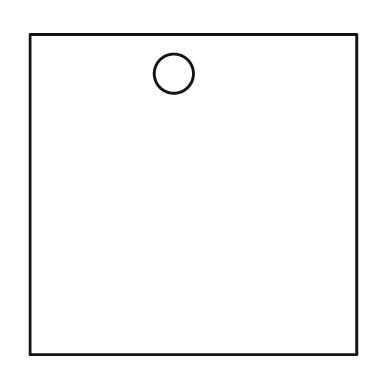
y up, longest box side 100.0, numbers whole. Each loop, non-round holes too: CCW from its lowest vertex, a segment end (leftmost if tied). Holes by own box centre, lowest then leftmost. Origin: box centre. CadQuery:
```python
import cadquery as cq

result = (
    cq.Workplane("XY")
    .moveTo(-50.0, -49.0)
    .lineTo(50.0, -49.0)
    .lineTo(50.0, 49.0)
    .lineTo(-50.0, 49.0)
    .close()
    .moveTo(-6.0, 37.0)
    .circle(6.0)
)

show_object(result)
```